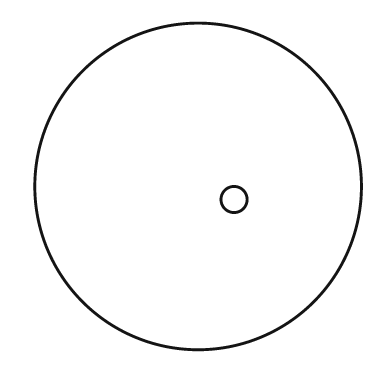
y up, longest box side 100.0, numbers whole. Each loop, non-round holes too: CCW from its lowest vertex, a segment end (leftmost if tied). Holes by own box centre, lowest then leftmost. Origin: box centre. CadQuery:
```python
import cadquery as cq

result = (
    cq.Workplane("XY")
    .moveTo(0.0, 0.0)
    .circle(50.0)
    .moveTo(11.0, -4.0)
    .circle(4.0)
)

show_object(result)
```